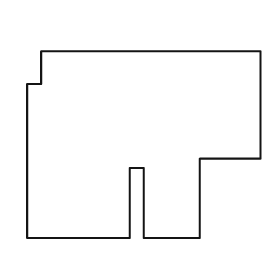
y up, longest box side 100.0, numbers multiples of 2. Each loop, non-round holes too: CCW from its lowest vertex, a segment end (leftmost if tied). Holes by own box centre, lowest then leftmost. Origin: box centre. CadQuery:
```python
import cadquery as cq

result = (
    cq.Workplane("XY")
    .moveTo(-50.0, -40.0)
    .lineTo(-6.0, -40.0)
    .lineTo(-6.0, -10.0)
    .lineTo(0.0, -10.0)
    .lineTo(0.0, -40.0)
    .lineTo(24.0, -40.0)
    .lineTo(24.0, -6.0)
    .lineTo(50.0, -6.0)
    .lineTo(50.0, 40.0)
    .lineTo(-44.0, 40.0)
    .lineTo(-44.0, 26.0)
    .lineTo(-50.0, 26.0)
    .close()
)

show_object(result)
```